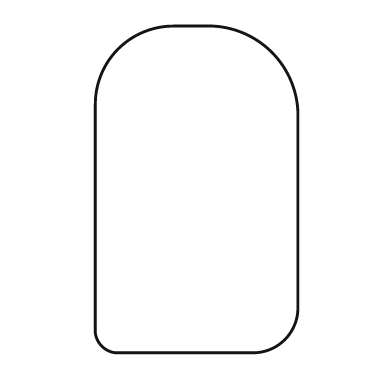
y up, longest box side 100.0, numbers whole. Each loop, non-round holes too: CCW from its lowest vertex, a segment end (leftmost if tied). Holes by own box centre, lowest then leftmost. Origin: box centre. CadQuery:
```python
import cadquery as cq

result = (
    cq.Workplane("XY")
    .moveTo(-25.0, -50.0)
    .lineTo(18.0, -50.0)
    .threePointArc((27.0, -46.0), (31.0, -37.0))
    .lineTo(31.0, 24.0)
    .threePointArc((23.0, 42.0), (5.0, 50.0))
    .lineTo(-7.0, 50.0)
    .threePointArc((-24.0, 43.0), (-31.0, 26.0))
    .lineTo(-31.0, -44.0)
    .threePointArc((-29.0, -48.0), (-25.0, -50.0))
    .close()
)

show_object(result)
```